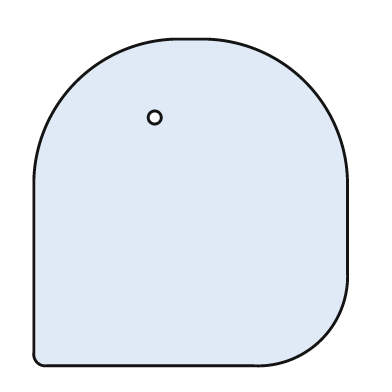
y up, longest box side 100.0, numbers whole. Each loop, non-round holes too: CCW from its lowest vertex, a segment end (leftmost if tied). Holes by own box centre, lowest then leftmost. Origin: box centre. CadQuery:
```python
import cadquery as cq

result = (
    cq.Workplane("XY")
    .moveTo(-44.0, -50.0)
    .lineTo(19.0, -50.0)
    .threePointArc((40.0, -42.0), (48.0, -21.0))
    .lineTo(48.0, 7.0)
    .threePointArc((35.0, 37.0), (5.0, 50.0))
    .lineTo(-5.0, 50.0)
    .threePointArc((-35.0, 37.0), (-48.0, 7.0))
    .lineTo(-48.0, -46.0)
    .threePointArc((-47.0, -49.0), (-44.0, -50.0))
    .close()
    .moveTo(-11.0, 26.0)
    .circle(2.0)
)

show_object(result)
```